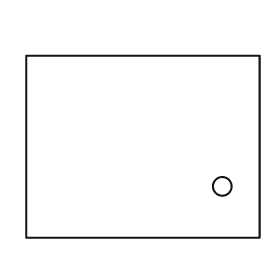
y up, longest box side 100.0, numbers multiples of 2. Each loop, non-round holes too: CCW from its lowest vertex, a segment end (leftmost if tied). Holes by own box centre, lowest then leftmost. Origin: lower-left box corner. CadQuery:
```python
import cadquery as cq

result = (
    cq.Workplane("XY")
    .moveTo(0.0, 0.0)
    .lineTo(100.0, 0.0)
    .lineTo(100.0, 78.0)
    .lineTo(0.0, 78.0)
    .close()
    .moveTo(84.0, 22.0)
    .circle(4.0)
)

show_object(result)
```